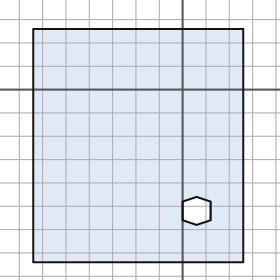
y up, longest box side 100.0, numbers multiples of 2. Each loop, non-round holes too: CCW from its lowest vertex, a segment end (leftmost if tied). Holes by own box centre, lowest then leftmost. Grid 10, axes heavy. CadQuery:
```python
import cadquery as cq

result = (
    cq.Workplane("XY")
    .moveTo(-64.0, -74.0)
    .lineTo(26.0, -74.0)
    .lineTo(26.0, 26.0)
    .lineTo(-64.0, 26.0)
    .close()
    .moveTo(6.0, -58.0)
    .lineTo(12.0, -56.0)
    .lineTo(12.0, -48.0)
    .lineTo(6.0, -46.0)
    .lineTo(0.0, -48.0)
    .lineTo(0.0, -56.0)
    .close()
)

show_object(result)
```